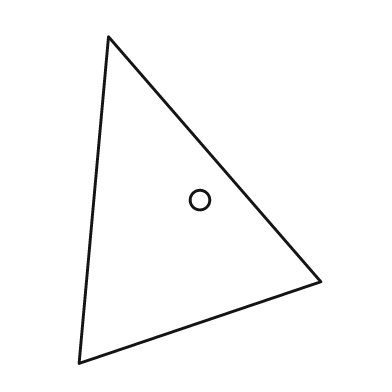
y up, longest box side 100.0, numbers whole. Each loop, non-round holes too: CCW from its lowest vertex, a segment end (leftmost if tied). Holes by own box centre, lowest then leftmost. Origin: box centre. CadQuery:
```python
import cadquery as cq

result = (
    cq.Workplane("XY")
    .moveTo(-37.0, -50.0)
    .lineTo(37.0, -25.0)
    .lineTo(-28.0, 50.0)
    .close()
    .moveTo(0.0, 0.0)
    .circle(3.0)
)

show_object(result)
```